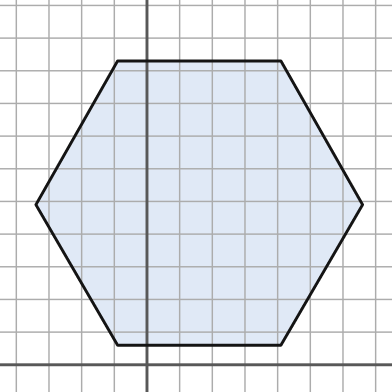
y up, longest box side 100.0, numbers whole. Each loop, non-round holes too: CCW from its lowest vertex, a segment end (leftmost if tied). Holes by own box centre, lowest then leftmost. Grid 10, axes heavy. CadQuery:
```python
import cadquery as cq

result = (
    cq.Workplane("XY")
    .moveTo(-9.0, 6.0)
    .lineTo(41.0, 6.0)
    .lineTo(66.0, 49.0)
    .lineTo(41.0, 93.0)
    .lineTo(-9.0, 93.0)
    .lineTo(-34.0, 49.0)
    .close()
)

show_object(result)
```